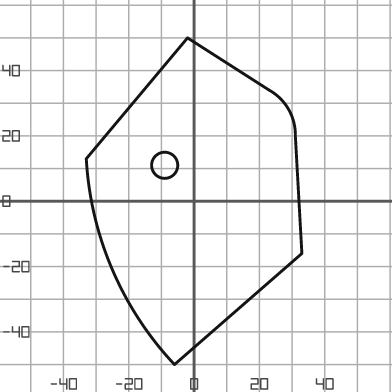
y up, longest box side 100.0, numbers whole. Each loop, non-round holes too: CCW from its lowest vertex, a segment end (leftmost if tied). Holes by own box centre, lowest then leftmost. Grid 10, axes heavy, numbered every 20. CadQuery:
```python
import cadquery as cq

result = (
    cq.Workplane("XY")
    .moveTo(-6.0, -50.0)
    .lineTo(33.0, -16.0)
    .lineTo(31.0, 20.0)
    .threePointArc((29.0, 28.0), (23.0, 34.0))
    .lineTo(-2.0, 50.0)
    .lineTo(-33.0, 13.0)
    .threePointArc((-25.0, -21.0), (-6.0, -50.0))
    .close()
    .moveTo(-9.0, 11.0)
    .circle(4.0)
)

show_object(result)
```